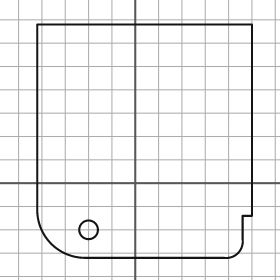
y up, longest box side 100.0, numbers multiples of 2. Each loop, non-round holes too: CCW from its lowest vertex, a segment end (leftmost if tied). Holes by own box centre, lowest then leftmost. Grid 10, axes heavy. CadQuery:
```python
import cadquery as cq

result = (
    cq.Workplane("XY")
    .moveTo(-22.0, -32.0)
    .lineTo(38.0, -32.0)
    .threePointArc((44.0, -30.0), (46.0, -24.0))
    .lineTo(46.0, -14.0)
    .lineTo(50.0, -14.0)
    .lineTo(50.0, 68.0)
    .lineTo(-42.0, 68.0)
    .lineTo(-42.0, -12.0)
    .threePointArc((-36.0, -26.0), (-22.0, -32.0))
    .close()
    .moveTo(-20.0, -20.0)
    .circle(4.0)
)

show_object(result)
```